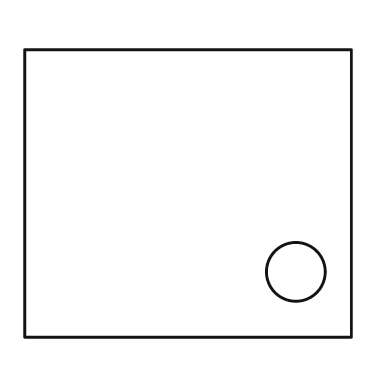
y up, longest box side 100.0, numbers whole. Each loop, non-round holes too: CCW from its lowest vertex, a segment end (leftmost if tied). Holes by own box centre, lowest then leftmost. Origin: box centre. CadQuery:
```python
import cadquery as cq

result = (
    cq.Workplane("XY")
    .moveTo(-50.0, -44.0)
    .lineTo(50.0, -44.0)
    .lineTo(50.0, 44.0)
    .lineTo(-50.0, 44.0)
    .close()
    .moveTo(33.0, -24.0)
    .circle(9.0)
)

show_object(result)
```